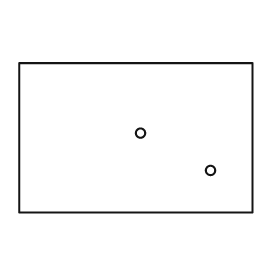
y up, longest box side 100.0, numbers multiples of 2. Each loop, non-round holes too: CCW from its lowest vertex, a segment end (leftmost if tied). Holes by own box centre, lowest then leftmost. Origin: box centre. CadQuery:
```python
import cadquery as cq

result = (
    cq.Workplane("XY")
    .moveTo(-50.0, -32.0)
    .lineTo(50.0, -32.0)
    .lineTo(50.0, 32.0)
    .lineTo(-50.0, 32.0)
    .close()
    .moveTo(32.0, -14.0)
    .circle(2.0)
    .moveTo(2.0, 2.0)
    .circle(2.0)
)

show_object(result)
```